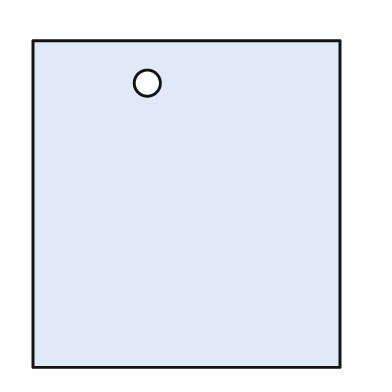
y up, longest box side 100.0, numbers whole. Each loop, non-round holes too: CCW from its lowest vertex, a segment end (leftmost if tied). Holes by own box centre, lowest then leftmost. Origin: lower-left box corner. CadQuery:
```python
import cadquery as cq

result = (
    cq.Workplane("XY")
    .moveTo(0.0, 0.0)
    .lineTo(94.0, 0.0)
    .lineTo(94.0, 100.0)
    .lineTo(0.0, 100.0)
    .close()
    .moveTo(35.0, 87.0)
    .circle(4.0)
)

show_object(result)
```